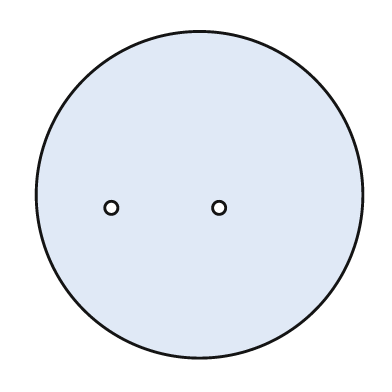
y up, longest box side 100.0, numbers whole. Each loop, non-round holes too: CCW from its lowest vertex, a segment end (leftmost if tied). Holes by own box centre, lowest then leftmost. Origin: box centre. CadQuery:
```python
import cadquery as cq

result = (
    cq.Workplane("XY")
    .moveTo(0.0, 0.0)
    .circle(50.0)
    .moveTo(-27.0, -4.0)
    .circle(2.0)
    .moveTo(6.0, -4.0)
    .circle(2.0)
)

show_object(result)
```